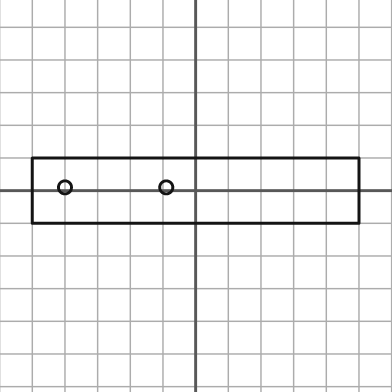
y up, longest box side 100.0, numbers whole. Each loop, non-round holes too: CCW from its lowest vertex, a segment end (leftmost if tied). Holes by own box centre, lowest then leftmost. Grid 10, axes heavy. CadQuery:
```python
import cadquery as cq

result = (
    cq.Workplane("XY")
    .moveTo(-50.0, -10.0)
    .lineTo(50.0, -10.0)
    .lineTo(50.0, 10.0)
    .lineTo(-50.0, 10.0)
    .close()
    .moveTo(-40.0, 1.0)
    .circle(2.0)
    .moveTo(-9.0, 1.0)
    .circle(2.0)
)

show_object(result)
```